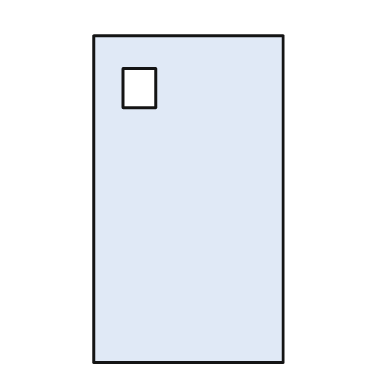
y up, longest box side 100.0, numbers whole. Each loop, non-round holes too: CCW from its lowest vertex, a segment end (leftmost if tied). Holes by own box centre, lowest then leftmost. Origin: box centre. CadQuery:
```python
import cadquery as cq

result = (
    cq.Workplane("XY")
    .moveTo(-29.0, -50.0)
    .lineTo(29.0, -50.0)
    .lineTo(29.0, 50.0)
    .lineTo(-29.0, 50.0)
    .close()
    .moveTo(-20.0, 28.0)
    .lineTo(-10.0, 28.0)
    .lineTo(-10.0, 40.0)
    .lineTo(-20.0, 40.0)
    .close()
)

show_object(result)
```